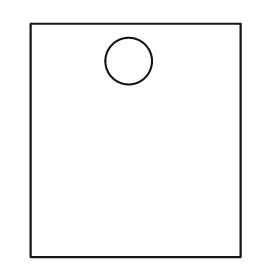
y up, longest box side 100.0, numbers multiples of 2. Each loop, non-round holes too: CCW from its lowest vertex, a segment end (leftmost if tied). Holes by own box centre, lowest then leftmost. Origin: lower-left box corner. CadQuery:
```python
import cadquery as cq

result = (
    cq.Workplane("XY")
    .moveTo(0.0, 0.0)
    .lineTo(90.0, 0.0)
    .lineTo(90.0, 100.0)
    .lineTo(0.0, 100.0)
    .close()
    .moveTo(42.0, 84.0)
    .circle(10.0)
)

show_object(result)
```